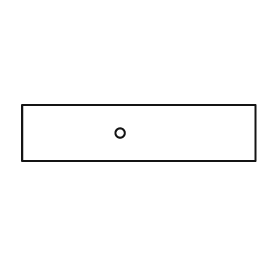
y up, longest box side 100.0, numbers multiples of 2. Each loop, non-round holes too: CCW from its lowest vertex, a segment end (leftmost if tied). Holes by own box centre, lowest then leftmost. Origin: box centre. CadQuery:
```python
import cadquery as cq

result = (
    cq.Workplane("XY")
    .moveTo(-50.0, -12.0)
    .lineTo(50.0, -12.0)
    .lineTo(50.0, 12.0)
    .lineTo(-50.0, 12.0)
    .close()
    .moveTo(-8.0, 0.0)
    .circle(2.0)
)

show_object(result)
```